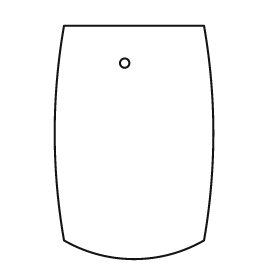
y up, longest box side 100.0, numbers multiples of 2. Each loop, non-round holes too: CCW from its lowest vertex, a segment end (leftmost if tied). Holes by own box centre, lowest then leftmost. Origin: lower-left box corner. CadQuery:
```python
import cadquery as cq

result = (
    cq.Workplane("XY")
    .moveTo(4.0, 8.0)
    .threePointArc((34.0, 0.0), (64.0, 8.0))
    .threePointArc((68.0, 54.0), (64.0, 100.0))
    .lineTo(4.0, 100.0)
    .threePointArc((0.0, 54.0), (4.0, 8.0))
    .close()
    .moveTo(30.0, 84.0)
    .circle(2.0)
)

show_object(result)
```